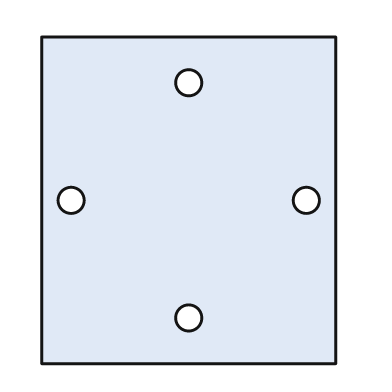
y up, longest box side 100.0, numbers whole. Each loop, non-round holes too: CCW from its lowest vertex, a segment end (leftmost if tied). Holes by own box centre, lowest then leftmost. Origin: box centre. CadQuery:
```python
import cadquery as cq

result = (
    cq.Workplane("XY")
    .moveTo(-45.0, -50.0)
    .lineTo(45.0, -50.0)
    .lineTo(45.0, 50.0)
    .lineTo(-45.0, 50.0)
    .close()
    .moveTo(0.0, -36.0)
    .circle(4.0)
    .moveTo(-36.0, 0.0)
    .circle(4.0)
    .moveTo(36.0, 0.0)
    .circle(4.0)
    .moveTo(0.0, 36.0)
    .circle(4.0)
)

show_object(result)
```